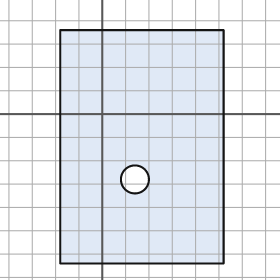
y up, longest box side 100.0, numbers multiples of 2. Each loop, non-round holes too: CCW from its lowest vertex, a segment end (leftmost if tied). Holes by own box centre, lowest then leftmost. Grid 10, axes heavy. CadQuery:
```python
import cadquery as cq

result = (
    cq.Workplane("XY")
    .moveTo(-18.0, -64.0)
    .lineTo(52.0, -64.0)
    .lineTo(52.0, 36.0)
    .lineTo(-18.0, 36.0)
    .close()
    .moveTo(14.0, -28.0)
    .circle(6.0)
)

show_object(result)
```